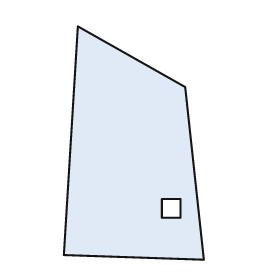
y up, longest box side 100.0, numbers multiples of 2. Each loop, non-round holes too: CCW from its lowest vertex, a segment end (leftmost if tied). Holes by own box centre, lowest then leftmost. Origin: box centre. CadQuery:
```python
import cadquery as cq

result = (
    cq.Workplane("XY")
    .moveTo(30.0, -50.0)
    .lineTo(22.0, 24.0)
    .lineTo(-24.0, 50.0)
    .lineTo(-30.0, -48.0)
    .close()
    .moveTo(12.0, -32.0)
    .lineTo(20.0, -32.0)
    .lineTo(20.0, -24.0)
    .lineTo(12.0, -24.0)
    .close()
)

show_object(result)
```